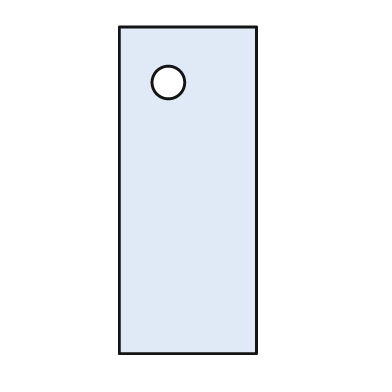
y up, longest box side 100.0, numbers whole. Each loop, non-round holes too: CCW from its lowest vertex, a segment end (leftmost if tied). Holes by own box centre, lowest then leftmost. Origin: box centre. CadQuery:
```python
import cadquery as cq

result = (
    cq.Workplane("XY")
    .moveTo(-21.0, -50.0)
    .lineTo(21.0, -50.0)
    .lineTo(21.0, 50.0)
    .lineTo(-21.0, 50.0)
    .close()
    .moveTo(-6.0, 33.0)
    .circle(5.0)
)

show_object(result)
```